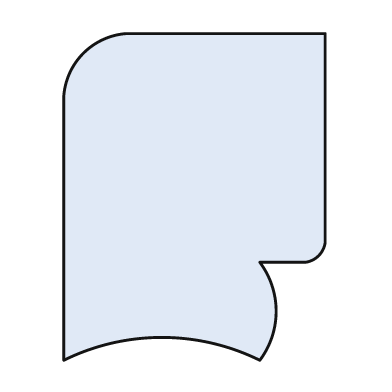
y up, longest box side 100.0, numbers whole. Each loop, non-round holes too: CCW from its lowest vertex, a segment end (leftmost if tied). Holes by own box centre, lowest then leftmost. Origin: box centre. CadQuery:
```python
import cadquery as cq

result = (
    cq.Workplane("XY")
    .moveTo(-40.0, -50.0)
    .threePointArc((-10.0, -43.0), (20.0, -50.0))
    .threePointArc((25.0, -35.0), (20.0, -20.0))
    .lineTo(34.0, -20.0)
    .threePointArc((38.0, -18.0), (40.0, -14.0))
    .lineTo(40.0, 50.0)
    .lineTo(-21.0, 50.0)
    .threePointArc((-34.0, 44.0), (-40.0, 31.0))
    .close()
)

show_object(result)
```